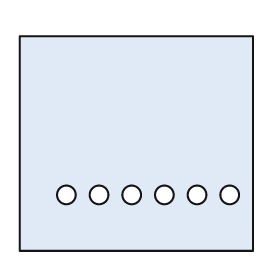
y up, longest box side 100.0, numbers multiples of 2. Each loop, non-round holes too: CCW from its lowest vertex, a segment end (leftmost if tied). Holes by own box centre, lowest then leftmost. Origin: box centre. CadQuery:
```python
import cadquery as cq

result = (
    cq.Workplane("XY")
    .moveTo(-50.0, -46.0)
    .lineTo(50.0, -46.0)
    .lineTo(50.0, 46.0)
    .lineTo(-50.0, 46.0)
    .close()
    .moveTo(-30.0, -22.0)
    .circle(4.0)
    .moveTo(-16.0, -22.0)
    .circle(4.0)
    .moveTo(-2.0, -22.0)
    .circle(4.0)
    .moveTo(12.0, -22.0)
    .circle(4.0)
    .moveTo(26.0, -22.0)
    .circle(4.0)
    .moveTo(40.0, -22.0)
    .circle(4.0)
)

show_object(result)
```